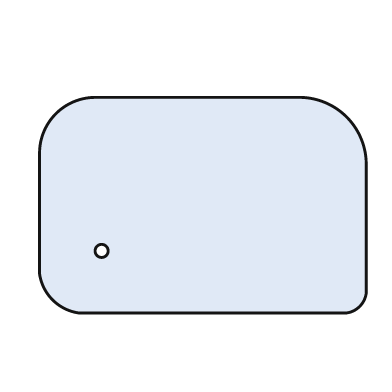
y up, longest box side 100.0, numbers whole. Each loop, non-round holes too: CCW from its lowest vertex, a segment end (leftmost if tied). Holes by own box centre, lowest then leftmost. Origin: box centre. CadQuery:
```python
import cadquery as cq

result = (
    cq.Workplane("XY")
    .moveTo(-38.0, -33.0)
    .lineTo(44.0, -33.0)
    .threePointArc((48.0, -31.0), (50.0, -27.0))
    .lineTo(50.0, 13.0)
    .threePointArc((44.0, 27.0), (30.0, 33.0))
    .lineTo(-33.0, 33.0)
    .threePointArc((-45.0, 28.0), (-50.0, 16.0))
    .lineTo(-50.0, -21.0)
    .threePointArc((-46.0, -29.0), (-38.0, -33.0))
    .close()
    .moveTo(-31.0, -14.0)
    .circle(2.0)
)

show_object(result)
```